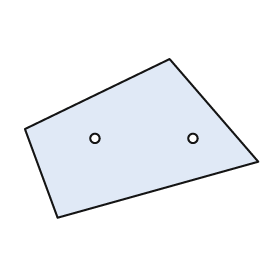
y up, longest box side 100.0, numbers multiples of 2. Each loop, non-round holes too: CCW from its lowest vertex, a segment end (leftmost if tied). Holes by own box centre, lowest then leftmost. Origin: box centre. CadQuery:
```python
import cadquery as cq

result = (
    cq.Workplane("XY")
    .moveTo(-36.0, -34.0)
    .lineTo(50.0, -10.0)
    .lineTo(12.0, 34.0)
    .lineTo(-50.0, 4.0)
    .close()
    .moveTo(-20.0, 0.0)
    .circle(2.0)
    .moveTo(22.0, 0.0)
    .circle(2.0)
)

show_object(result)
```